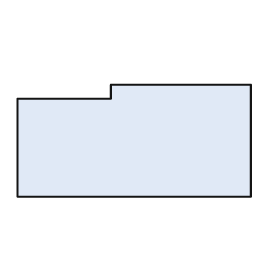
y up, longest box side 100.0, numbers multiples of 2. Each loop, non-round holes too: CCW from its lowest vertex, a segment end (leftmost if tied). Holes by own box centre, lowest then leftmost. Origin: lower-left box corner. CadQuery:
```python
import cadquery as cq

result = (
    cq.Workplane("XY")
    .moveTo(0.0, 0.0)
    .lineTo(100.0, 0.0)
    .lineTo(100.0, 48.0)
    .lineTo(40.0, 48.0)
    .lineTo(40.0, 42.0)
    .lineTo(0.0, 42.0)
    .close()
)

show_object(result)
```